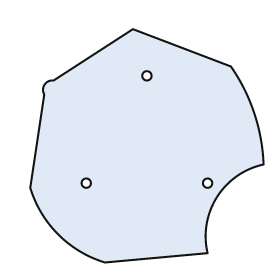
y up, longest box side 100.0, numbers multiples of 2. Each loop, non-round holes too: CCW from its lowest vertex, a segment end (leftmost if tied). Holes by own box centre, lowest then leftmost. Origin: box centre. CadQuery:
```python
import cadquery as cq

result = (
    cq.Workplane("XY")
    .moveTo(-18.0, -50.0)
    .lineTo(26.0, -46.0)
    .threePointArc((30.0, -22.0), (50.0, -8.0))
    .threePointArc((46.0, 14.0), (36.0, 34.0))
    .lineTo(-6.0, 50.0)
    .lineTo(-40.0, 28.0)
    .threePointArc((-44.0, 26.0), (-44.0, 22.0))
    .lineTo(-50.0, -18.0)
    .threePointArc((-38.0, -38.0), (-18.0, -50.0))
    .close()
    .moveTo(-26.0, -16.0)
    .circle(2.0)
    .moveTo(26.0, -16.0)
    .circle(2.0)
    .moveTo(0.0, 30.0)
    .circle(2.0)
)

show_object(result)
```